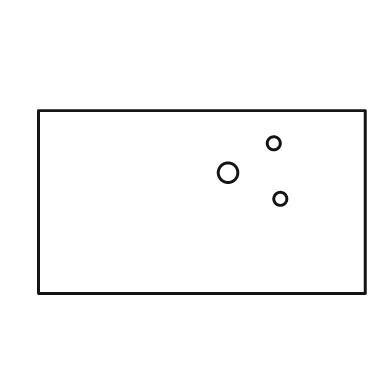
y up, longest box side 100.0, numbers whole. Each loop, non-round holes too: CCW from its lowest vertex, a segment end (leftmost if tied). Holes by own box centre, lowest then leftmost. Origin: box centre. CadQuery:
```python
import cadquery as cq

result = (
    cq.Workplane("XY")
    .moveTo(-50.0, -28.0)
    .lineTo(50.0, -28.0)
    .lineTo(50.0, 28.0)
    .lineTo(-50.0, 28.0)
    .close()
    .moveTo(24.0, 1.0)
    .circle(2.0)
    .moveTo(8.0, 9.0)
    .circle(3.0)
    .moveTo(22.0, 18.0)
    .circle(2.0)
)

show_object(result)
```